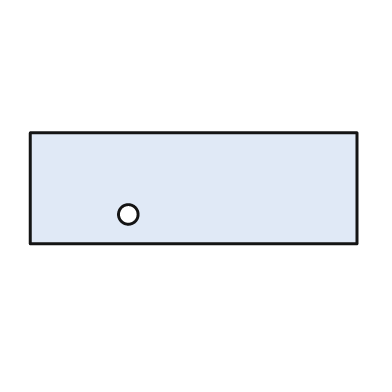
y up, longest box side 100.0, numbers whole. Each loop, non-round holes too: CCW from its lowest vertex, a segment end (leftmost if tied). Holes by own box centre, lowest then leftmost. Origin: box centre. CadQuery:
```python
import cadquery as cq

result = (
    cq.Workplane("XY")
    .moveTo(-50.0, -17.0)
    .lineTo(50.0, -17.0)
    .lineTo(50.0, 17.0)
    .lineTo(-50.0, 17.0)
    .close()
    .moveTo(-20.0, -8.0)
    .circle(3.0)
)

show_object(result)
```